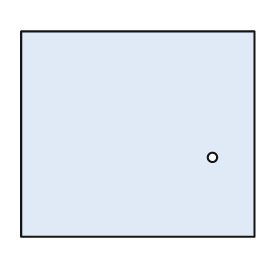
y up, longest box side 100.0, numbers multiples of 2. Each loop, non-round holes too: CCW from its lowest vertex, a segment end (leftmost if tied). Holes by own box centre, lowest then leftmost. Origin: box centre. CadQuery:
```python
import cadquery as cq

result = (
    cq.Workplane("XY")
    .moveTo(-50.0, -44.0)
    .lineTo(50.0, -44.0)
    .lineTo(50.0, 44.0)
    .lineTo(-50.0, 44.0)
    .close()
    .moveTo(32.0, -10.0)
    .circle(2.0)
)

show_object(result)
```